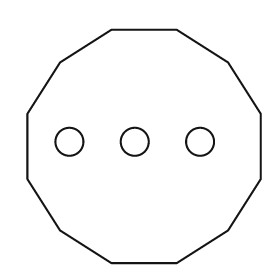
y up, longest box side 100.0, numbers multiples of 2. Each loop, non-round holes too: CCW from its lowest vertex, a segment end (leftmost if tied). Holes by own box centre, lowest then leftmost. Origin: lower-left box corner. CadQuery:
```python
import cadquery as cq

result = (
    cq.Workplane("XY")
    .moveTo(36.0, 0.0)
    .lineTo(64.0, 0.0)
    .lineTo(86.0, 14.0)
    .lineTo(100.0, 36.0)
    .lineTo(100.0, 64.0)
    .lineTo(86.0, 86.0)
    .lineTo(64.0, 100.0)
    .lineTo(36.0, 100.0)
    .lineTo(14.0, 86.0)
    .lineTo(0.0, 64.0)
    .lineTo(0.0, 36.0)
    .lineTo(14.0, 14.0)
    .close()
    .moveTo(18.0, 52.0)
    .circle(6.0)
    .moveTo(46.0, 52.0)
    .circle(6.0)
    .moveTo(74.0, 52.0)
    .circle(6.0)
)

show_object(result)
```